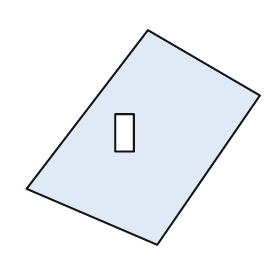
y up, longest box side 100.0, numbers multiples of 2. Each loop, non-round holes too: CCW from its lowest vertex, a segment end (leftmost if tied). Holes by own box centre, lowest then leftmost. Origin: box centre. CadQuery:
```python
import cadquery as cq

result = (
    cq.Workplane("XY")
    .moveTo(6.0, -46.0)
    .lineTo(50.0, 18.0)
    .lineTo(2.0, 46.0)
    .lineTo(-50.0, -22.0)
    .close()
    .moveTo(-12.0, -6.0)
    .lineTo(-4.0, -6.0)
    .lineTo(-4.0, 10.0)
    .lineTo(-12.0, 10.0)
    .close()
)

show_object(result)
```